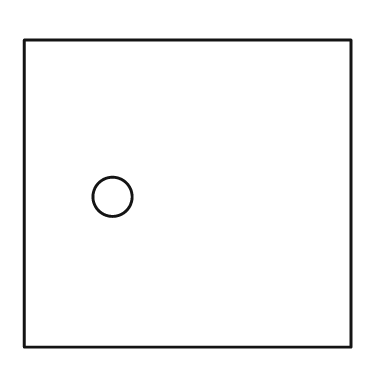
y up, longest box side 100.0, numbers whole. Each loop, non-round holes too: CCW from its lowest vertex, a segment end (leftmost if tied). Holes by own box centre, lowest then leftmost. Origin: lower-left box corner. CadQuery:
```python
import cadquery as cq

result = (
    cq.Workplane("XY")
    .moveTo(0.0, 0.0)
    .lineTo(100.0, 0.0)
    .lineTo(100.0, 94.0)
    .lineTo(0.0, 94.0)
    .close()
    .moveTo(27.0, 46.0)
    .circle(6.0)
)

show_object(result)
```